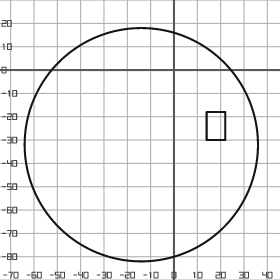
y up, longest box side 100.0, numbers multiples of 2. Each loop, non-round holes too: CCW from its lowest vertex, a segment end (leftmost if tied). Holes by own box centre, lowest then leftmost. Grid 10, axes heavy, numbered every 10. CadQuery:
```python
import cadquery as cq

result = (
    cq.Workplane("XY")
    .moveTo(-14.0, -32.0)
    .circle(50.0)
    .moveTo(14.0, -30.0)
    .lineTo(22.0, -30.0)
    .lineTo(22.0, -18.0)
    .lineTo(14.0, -18.0)
    .close()
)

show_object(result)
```